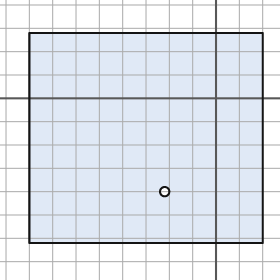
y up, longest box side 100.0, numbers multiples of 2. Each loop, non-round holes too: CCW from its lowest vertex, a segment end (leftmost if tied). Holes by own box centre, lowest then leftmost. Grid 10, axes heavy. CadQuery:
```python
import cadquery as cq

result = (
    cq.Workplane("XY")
    .moveTo(-80.0, -62.0)
    .lineTo(20.0, -62.0)
    .lineTo(20.0, 28.0)
    .lineTo(-80.0, 28.0)
    .close()
    .moveTo(-22.0, -40.0)
    .circle(2.0)
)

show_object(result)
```